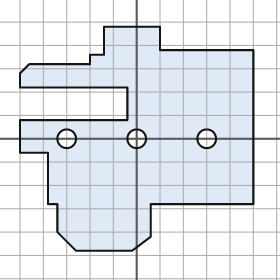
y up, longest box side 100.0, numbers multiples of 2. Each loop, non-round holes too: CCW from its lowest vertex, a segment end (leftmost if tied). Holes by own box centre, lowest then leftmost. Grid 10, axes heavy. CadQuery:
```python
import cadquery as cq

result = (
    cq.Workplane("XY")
    .moveTo(-26.0, -48.0)
    .lineTo(-2.0, -48.0)
    .lineTo(6.0, -42.0)
    .lineTo(6.0, -28.0)
    .lineTo(50.0, -28.0)
    .lineTo(50.0, 38.0)
    .lineTo(10.0, 38.0)
    .lineTo(10.0, 48.0)
    .lineTo(-14.0, 48.0)
    .lineTo(-14.0, 36.0)
    .lineTo(-20.0, 36.0)
    .lineTo(-20.0, 32.0)
    .lineTo(-46.0, 32.0)
    .lineTo(-50.0, 28.0)
    .lineTo(-50.0, 22.0)
    .lineTo(-4.0, 22.0)
    .lineTo(-4.0, 8.0)
    .lineTo(-50.0, 8.0)
    .lineTo(-50.0, -6.0)
    .lineTo(-38.0, -6.0)
    .lineTo(-38.0, -28.0)
    .lineTo(-34.0, -28.0)
    .lineTo(-34.0, -40.0)
    .close()
    .moveTo(-30.0, 0.0)
    .circle(4.0)
    .moveTo(0.0, 0.0)
    .circle(4.0)
    .moveTo(30.0, 0.0)
    .circle(4.0)
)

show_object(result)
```